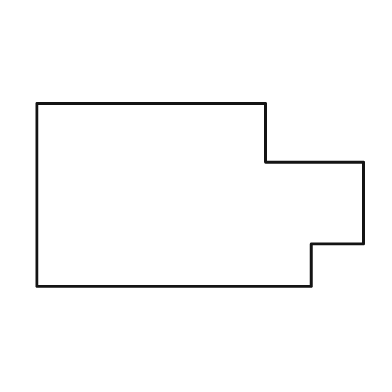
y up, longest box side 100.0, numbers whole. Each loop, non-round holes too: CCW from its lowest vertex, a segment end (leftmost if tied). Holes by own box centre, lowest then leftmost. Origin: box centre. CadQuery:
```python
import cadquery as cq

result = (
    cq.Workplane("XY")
    .moveTo(-50.0, -28.0)
    .lineTo(34.0, -28.0)
    .lineTo(34.0, -15.0)
    .lineTo(50.0, -15.0)
    .lineTo(50.0, 10.0)
    .lineTo(20.0, 10.0)
    .lineTo(20.0, 28.0)
    .lineTo(-50.0, 28.0)
    .close()
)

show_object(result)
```